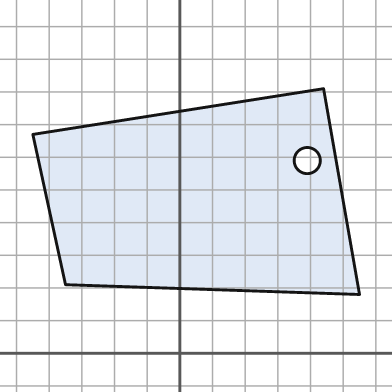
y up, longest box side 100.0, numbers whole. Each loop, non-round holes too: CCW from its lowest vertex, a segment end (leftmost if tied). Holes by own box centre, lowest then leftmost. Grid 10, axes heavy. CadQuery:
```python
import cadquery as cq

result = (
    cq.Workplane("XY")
    .moveTo(55.0, 18.0)
    .lineTo(44.0, 81.0)
    .lineTo(-45.0, 67.0)
    .lineTo(-35.0, 21.0)
    .close()
    .moveTo(39.0, 59.0)
    .circle(4.0)
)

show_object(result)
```